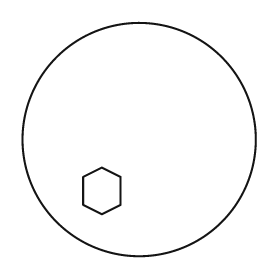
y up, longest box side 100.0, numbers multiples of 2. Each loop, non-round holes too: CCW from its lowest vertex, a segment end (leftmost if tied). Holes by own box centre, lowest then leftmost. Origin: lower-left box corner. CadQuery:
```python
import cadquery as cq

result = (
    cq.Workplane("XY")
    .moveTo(50.0, 50.0)
    .circle(50.0)
    .moveTo(34.0, 18.0)
    .lineTo(42.0, 22.0)
    .lineTo(42.0, 34.0)
    .lineTo(34.0, 38.0)
    .lineTo(26.0, 34.0)
    .lineTo(26.0, 22.0)
    .close()
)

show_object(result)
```